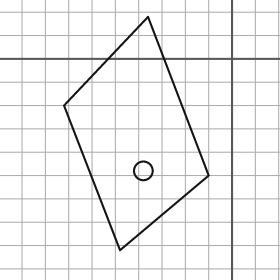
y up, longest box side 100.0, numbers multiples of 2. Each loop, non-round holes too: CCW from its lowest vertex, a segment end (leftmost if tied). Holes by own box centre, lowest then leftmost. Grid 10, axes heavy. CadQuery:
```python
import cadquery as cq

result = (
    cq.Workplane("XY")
    .moveTo(-48.0, -82.0)
    .lineTo(-10.0, -50.0)
    .lineTo(-36.0, 18.0)
    .lineTo(-72.0, -20.0)
    .close()
    .moveTo(-38.0, -48.0)
    .circle(4.0)
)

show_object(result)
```